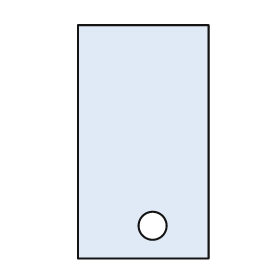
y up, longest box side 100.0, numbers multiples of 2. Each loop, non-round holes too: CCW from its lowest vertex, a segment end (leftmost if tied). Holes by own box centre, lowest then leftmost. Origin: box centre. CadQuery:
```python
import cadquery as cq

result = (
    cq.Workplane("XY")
    .moveTo(-28.0, -50.0)
    .lineTo(28.0, -50.0)
    .lineTo(28.0, 50.0)
    .lineTo(-28.0, 50.0)
    .close()
    .moveTo(4.0, -36.0)
    .circle(6.0)
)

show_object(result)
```